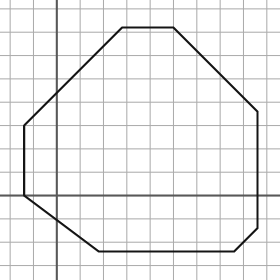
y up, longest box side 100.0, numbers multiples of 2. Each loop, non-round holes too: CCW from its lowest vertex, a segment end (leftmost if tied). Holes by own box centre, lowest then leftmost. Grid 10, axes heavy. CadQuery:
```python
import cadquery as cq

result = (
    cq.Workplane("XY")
    .moveTo(18.0, -24.0)
    .lineTo(76.0, -24.0)
    .lineTo(86.0, -14.0)
    .lineTo(86.0, 36.0)
    .lineTo(50.0, 72.0)
    .lineTo(28.0, 72.0)
    .lineTo(-14.0, 30.0)
    .lineTo(-14.0, 0.0)
    .close()
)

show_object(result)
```